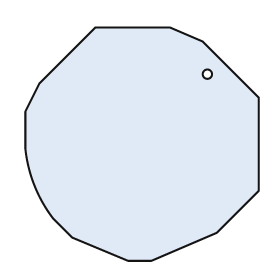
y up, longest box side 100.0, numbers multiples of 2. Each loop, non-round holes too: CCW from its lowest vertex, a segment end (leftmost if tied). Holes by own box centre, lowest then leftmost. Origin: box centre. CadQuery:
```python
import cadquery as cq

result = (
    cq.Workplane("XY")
    .moveTo(-6.0, -50.0)
    .lineTo(4.0, -50.0)
    .lineTo(32.0, -38.0)
    .lineTo(50.0, -20.0)
    .lineTo(50.0, 20.0)
    .lineTo(26.0, 44.0)
    .lineTo(12.0, 50.0)
    .lineTo(-20.0, 50.0)
    .lineTo(-44.0, 26.0)
    .lineTo(-50.0, 14.0)
    .lineTo(-50.0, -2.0)
    .threePointArc((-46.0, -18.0), (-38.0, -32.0))
    .lineTo(-30.0, -40.0)
    .close()
    .moveTo(28.0, 30.0)
    .circle(2.0)
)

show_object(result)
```